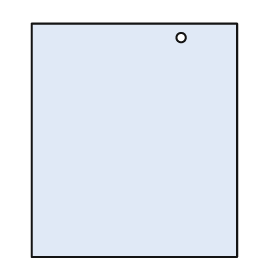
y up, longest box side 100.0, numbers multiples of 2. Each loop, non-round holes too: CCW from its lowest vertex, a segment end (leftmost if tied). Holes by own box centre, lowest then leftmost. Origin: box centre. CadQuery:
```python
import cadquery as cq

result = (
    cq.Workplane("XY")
    .moveTo(-44.0, -50.0)
    .lineTo(44.0, -50.0)
    .lineTo(44.0, 50.0)
    .lineTo(-44.0, 50.0)
    .close()
    .moveTo(20.0, 44.0)
    .circle(2.0)
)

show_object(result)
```